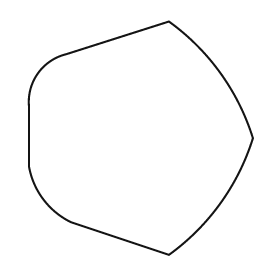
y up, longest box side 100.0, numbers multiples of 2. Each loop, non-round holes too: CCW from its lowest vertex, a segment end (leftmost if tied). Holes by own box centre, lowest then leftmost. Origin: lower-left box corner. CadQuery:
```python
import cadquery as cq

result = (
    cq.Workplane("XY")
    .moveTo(60.0, 0.0)
    .threePointArc((82.0, 22.0), (96.0, 50.0))
    .threePointArc((82.0, 78.0), (60.0, 100.0))
    .lineTo(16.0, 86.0)
    .threePointArc((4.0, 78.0), (0.0, 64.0))
    .lineTo(0.0, 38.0)
    .threePointArc((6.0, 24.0), (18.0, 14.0))
    .close()
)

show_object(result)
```